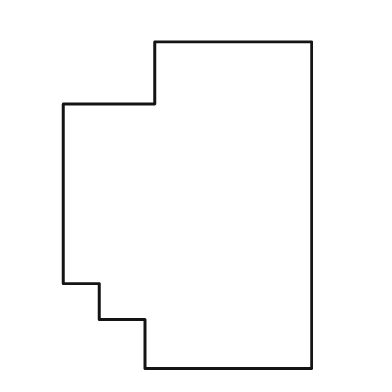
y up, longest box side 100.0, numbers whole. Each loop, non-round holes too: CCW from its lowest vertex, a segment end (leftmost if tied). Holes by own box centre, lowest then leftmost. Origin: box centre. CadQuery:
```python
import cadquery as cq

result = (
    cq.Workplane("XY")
    .moveTo(-13.0, -50.0)
    .lineTo(38.0, -50.0)
    .lineTo(38.0, 50.0)
    .lineTo(-10.0, 50.0)
    .lineTo(-10.0, 31.0)
    .lineTo(-38.0, 31.0)
    .lineTo(-38.0, -24.0)
    .lineTo(-27.0, -24.0)
    .lineTo(-27.0, -35.0)
    .lineTo(-13.0, -35.0)
    .close()
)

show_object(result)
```